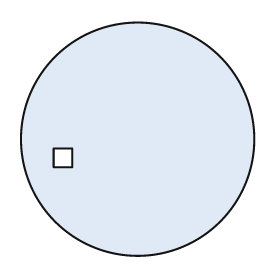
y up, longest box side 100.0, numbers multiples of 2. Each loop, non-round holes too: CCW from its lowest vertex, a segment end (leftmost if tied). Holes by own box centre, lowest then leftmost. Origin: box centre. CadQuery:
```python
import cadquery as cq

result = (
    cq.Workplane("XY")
    .moveTo(0.0, 0.0)
    .circle(50.0)
    .moveTo(-36.0, -12.0)
    .lineTo(-28.0, -12.0)
    .lineTo(-28.0, -4.0)
    .lineTo(-36.0, -4.0)
    .close()
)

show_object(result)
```